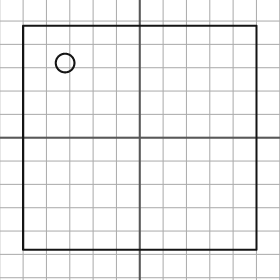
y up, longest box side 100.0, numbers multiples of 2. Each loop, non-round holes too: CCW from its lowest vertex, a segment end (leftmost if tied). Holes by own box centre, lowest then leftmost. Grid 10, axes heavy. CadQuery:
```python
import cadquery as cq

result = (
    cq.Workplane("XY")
    .moveTo(-50.0, -48.0)
    .lineTo(50.0, -48.0)
    .lineTo(50.0, 48.0)
    .lineTo(-50.0, 48.0)
    .close()
    .moveTo(-32.0, 32.0)
    .circle(4.0)
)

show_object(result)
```